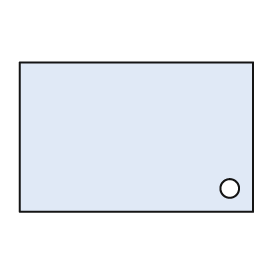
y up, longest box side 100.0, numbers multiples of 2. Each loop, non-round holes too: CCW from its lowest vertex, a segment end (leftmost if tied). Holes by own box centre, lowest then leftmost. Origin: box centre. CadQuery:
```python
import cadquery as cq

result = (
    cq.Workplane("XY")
    .moveTo(-50.0, -32.0)
    .lineTo(50.0, -32.0)
    .lineTo(50.0, 32.0)
    .lineTo(-50.0, 32.0)
    .close()
    .moveTo(40.0, -22.0)
    .circle(4.0)
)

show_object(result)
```